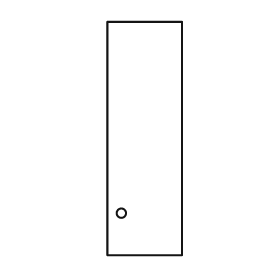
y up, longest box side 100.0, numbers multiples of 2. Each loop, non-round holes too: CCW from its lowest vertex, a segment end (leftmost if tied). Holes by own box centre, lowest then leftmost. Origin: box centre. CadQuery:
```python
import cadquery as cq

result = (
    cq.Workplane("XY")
    .moveTo(-16.0, -50.0)
    .lineTo(16.0, -50.0)
    .lineTo(16.0, 50.0)
    .lineTo(-16.0, 50.0)
    .close()
    .moveTo(-10.0, -32.0)
    .circle(2.0)
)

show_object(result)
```